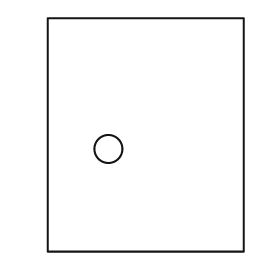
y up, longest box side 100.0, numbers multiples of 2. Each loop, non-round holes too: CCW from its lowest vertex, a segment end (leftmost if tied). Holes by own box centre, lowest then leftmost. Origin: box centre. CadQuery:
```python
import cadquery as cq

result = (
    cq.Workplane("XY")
    .moveTo(-42.0, -50.0)
    .lineTo(42.0, -50.0)
    .lineTo(42.0, 50.0)
    .lineTo(-42.0, 50.0)
    .close()
    .moveTo(-16.0, -6.0)
    .circle(6.0)
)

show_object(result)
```